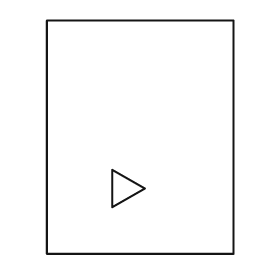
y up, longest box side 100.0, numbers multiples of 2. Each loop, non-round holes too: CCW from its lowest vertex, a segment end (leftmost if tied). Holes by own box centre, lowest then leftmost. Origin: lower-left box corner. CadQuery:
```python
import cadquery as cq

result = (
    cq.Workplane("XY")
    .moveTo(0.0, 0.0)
    .lineTo(80.0, 0.0)
    .lineTo(80.0, 100.0)
    .lineTo(0.0, 100.0)
    .close()
    .moveTo(28.0, 20.0)
    .lineTo(42.0, 28.0)
    .lineTo(28.0, 36.0)
    .close()
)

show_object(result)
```